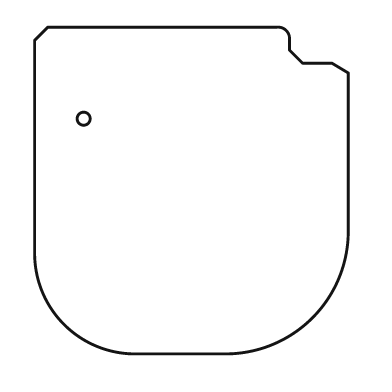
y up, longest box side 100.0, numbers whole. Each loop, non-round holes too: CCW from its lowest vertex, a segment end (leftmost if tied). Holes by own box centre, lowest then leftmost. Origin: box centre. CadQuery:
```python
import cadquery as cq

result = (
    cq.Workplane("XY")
    .moveTo(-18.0, -50.0)
    .lineTo(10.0, -50.0)
    .threePointArc((37.0, -39.0), (48.0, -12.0))
    .lineTo(48.0, 36.0)
    .lineTo(43.0, 39.0)
    .lineTo(34.0, 39.0)
    .lineTo(30.0, 43.0)
    .lineTo(30.0, 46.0)
    .threePointArc((29.0, 49.0), (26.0, 50.0))
    .lineTo(-44.0, 50.0)
    .lineTo(-48.0, 46.0)
    .lineTo(-48.0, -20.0)
    .threePointArc((-39.0, -41.0), (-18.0, -50.0))
    .close()
    .moveTo(-33.0, 22.0)
    .circle(2.0)
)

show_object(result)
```